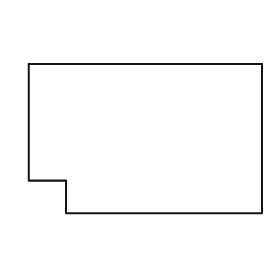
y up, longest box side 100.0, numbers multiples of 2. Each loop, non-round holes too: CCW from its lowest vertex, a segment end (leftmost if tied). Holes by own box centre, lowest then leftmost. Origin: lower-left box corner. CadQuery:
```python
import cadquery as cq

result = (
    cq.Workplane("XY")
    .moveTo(16.0, 0.0)
    .lineTo(100.0, 0.0)
    .lineTo(100.0, 64.0)
    .lineTo(0.0, 64.0)
    .lineTo(0.0, 14.0)
    .lineTo(16.0, 14.0)
    .close()
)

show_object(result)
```